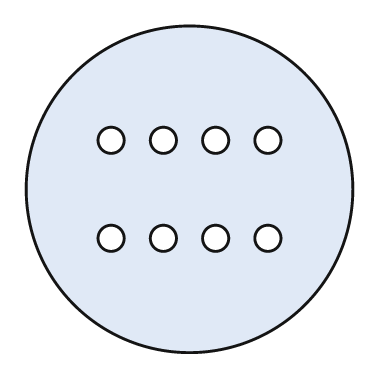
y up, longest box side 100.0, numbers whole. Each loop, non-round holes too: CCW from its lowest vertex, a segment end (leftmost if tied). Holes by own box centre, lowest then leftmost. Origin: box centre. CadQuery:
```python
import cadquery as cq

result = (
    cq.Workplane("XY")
    .moveTo(0.0, 0.0)
    .circle(50.0)
    .moveTo(-24.0, -15.0)
    .circle(4.0)
    .moveTo(-8.0, -15.0)
    .circle(4.0)
    .moveTo(8.0, -15.0)
    .circle(4.0)
    .moveTo(24.0, -15.0)
    .circle(4.0)
    .moveTo(-24.0, 15.0)
    .circle(4.0)
    .moveTo(-8.0, 15.0)
    .circle(4.0)
    .moveTo(8.0, 15.0)
    .circle(4.0)
    .moveTo(24.0, 15.0)
    .circle(4.0)
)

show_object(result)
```